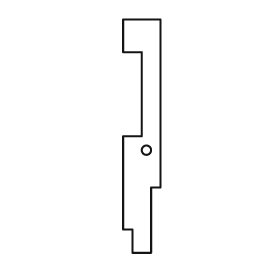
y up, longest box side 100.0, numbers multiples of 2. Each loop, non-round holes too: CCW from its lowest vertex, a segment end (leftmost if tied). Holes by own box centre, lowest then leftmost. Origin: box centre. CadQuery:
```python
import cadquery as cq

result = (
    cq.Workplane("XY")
    .moveTo(-4.0, -50.0)
    .lineTo(4.0, -50.0)
    .lineTo(4.0, -22.0)
    .lineTo(8.0, -22.0)
    .lineTo(8.0, 50.0)
    .lineTo(-8.0, 50.0)
    .lineTo(-8.0, 36.0)
    .lineTo(0.0, 36.0)
    .lineTo(0.0, 0.0)
    .lineTo(-8.0, 0.0)
    .lineTo(-8.0, -40.0)
    .lineTo(-4.0, -40.0)
    .close()
    .moveTo(2.0, -6.0)
    .circle(2.0)
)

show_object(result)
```